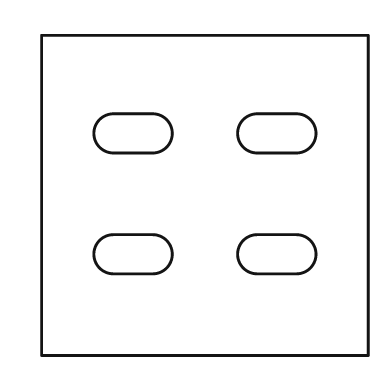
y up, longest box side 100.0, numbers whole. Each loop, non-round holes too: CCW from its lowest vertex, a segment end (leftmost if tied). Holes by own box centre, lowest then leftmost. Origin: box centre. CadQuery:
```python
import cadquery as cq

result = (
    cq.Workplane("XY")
    .moveTo(-50.0, -49.0)
    .lineTo(50.0, -49.0)
    .lineTo(50.0, 49.0)
    .lineTo(-50.0, 49.0)
    .close()
    .moveTo(-28.0, -24.0)
    .lineTo(-16.0, -24.0)
    .threePointArc((-10.0, -18.0), (-16.0, -12.0))
    .lineTo(-28.0, -12.0)
    .threePointArc((-34.0, -18.0), (-28.0, -24.0))
    .close()
    .moveTo(16.0, -24.0)
    .lineTo(28.0, -24.0)
    .threePointArc((34.0, -18.0), (28.0, -12.0))
    .lineTo(16.0, -12.0)
    .threePointArc((10.0, -18.0), (16.0, -24.0))
    .close()
    .moveTo(-28.0, 13.0)
    .lineTo(-16.0, 13.0)
    .threePointArc((-10.0, 19.0), (-16.0, 25.0))
    .lineTo(-28.0, 25.0)
    .threePointArc((-34.0, 19.0), (-28.0, 13.0))
    .close()
    .moveTo(16.0, 13.0)
    .lineTo(28.0, 13.0)
    .threePointArc((34.0, 19.0), (28.0, 25.0))
    .lineTo(16.0, 25.0)
    .threePointArc((10.0, 19.0), (16.0, 13.0))
    .close()
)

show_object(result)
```